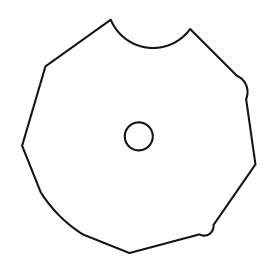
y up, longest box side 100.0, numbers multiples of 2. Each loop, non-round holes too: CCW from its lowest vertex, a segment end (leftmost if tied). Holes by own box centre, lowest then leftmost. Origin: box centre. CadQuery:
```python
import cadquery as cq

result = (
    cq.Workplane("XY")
    .moveTo(-4.0, -50.0)
    .lineTo(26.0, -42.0)
    .threePointArc((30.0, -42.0), (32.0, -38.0))
    .lineTo(50.0, -12.0)
    .lineTo(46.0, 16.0)
    .threePointArc((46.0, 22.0), (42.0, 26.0))
    .lineTo(22.0, 46.0)
    .threePointArc((4.0, 38.0), (-12.0, 50.0))
    .lineTo(-40.0, 30.0)
    .lineTo(-50.0, -4.0)
    .lineTo(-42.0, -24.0)
    .threePointArc((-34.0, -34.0), (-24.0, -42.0))
    .close()
    .moveTo(0.0, 0.0)
    .circle(6.0)
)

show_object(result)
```